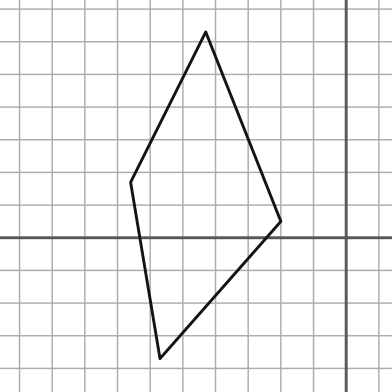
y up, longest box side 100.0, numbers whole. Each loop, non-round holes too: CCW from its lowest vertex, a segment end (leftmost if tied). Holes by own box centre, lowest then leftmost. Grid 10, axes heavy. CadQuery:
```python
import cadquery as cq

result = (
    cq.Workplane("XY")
    .moveTo(-57.0, -37.0)
    .lineTo(-20.0, 5.0)
    .lineTo(-43.0, 63.0)
    .lineTo(-66.0, 17.0)
    .close()
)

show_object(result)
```